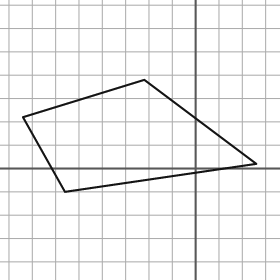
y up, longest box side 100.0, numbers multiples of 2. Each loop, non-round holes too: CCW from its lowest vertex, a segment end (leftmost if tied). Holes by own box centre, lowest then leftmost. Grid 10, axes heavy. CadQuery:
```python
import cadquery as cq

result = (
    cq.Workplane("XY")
    .moveTo(-56.0, -10.0)
    .lineTo(26.0, 2.0)
    .lineTo(-22.0, 38.0)
    .lineTo(-74.0, 22.0)
    .close()
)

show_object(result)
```